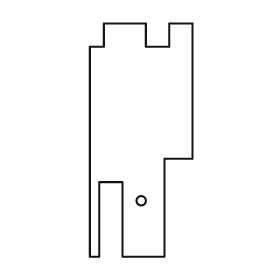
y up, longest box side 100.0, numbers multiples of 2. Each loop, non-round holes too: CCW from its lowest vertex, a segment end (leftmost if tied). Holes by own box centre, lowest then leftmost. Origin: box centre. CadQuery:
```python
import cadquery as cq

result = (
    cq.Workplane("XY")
    .moveTo(-22.0, -50.0)
    .lineTo(-18.0, -50.0)
    .lineTo(-18.0, -18.0)
    .lineTo(-8.0, -18.0)
    .lineTo(-8.0, -50.0)
    .lineTo(10.0, -50.0)
    .lineTo(10.0, -8.0)
    .lineTo(22.0, -8.0)
    .lineTo(22.0, 50.0)
    .lineTo(12.0, 50.0)
    .lineTo(12.0, 40.0)
    .lineTo(2.0, 40.0)
    .lineTo(2.0, 50.0)
    .lineTo(-16.0, 50.0)
    .lineTo(-16.0, 40.0)
    .lineTo(-22.0, 40.0)
    .close()
    .moveTo(0.0, -26.0)
    .circle(2.0)
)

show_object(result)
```